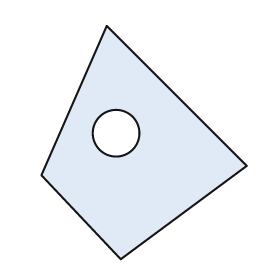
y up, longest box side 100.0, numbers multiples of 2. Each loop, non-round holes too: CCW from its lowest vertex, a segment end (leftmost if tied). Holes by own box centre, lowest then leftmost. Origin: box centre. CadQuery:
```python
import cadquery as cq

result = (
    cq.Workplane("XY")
    .moveTo(-10.0, -50.0)
    .lineTo(44.0, -10.0)
    .lineTo(-16.0, 50.0)
    .lineTo(-44.0, -14.0)
    .close()
    .moveTo(-12.0, 4.0)
    .circle(10.0)
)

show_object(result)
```